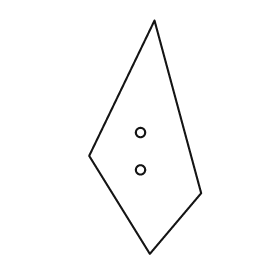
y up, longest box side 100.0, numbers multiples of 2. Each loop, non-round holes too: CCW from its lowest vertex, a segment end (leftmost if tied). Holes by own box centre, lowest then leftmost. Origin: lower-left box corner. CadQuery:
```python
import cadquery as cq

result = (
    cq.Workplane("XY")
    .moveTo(26.0, 0.0)
    .lineTo(48.0, 26.0)
    .lineTo(28.0, 100.0)
    .lineTo(0.0, 42.0)
    .close()
    .moveTo(22.0, 36.0)
    .circle(2.0)
    .moveTo(22.0, 52.0)
    .circle(2.0)
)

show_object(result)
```